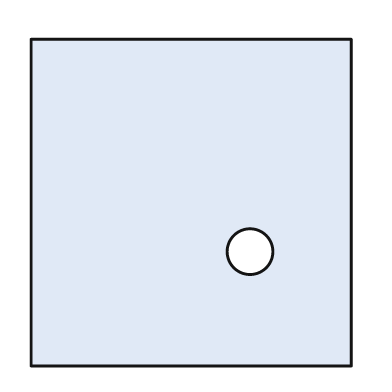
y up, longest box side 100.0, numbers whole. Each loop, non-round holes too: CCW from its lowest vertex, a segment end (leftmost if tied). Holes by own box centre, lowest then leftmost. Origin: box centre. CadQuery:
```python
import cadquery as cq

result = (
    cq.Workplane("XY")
    .moveTo(-49.0, -50.0)
    .lineTo(49.0, -50.0)
    .lineTo(49.0, 50.0)
    .lineTo(-49.0, 50.0)
    .close()
    .moveTo(18.0, -15.0)
    .circle(7.0)
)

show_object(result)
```